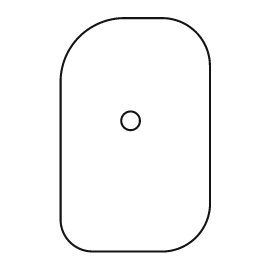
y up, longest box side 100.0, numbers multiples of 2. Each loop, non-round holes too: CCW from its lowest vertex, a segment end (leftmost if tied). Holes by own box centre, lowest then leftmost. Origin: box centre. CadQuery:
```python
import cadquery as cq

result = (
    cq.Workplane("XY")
    .moveTo(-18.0, -50.0)
    .lineTo(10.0, -50.0)
    .threePointArc((26.0, -44.0), (32.0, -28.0))
    .lineTo(32.0, 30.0)
    .threePointArc((26.0, 44.0), (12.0, 50.0))
    .lineTo(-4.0, 50.0)
    .threePointArc((-24.0, 42.0), (-32.0, 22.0))
    .lineTo(-32.0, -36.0)
    .threePointArc((-28.0, -46.0), (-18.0, -50.0))
    .close()
    .moveTo(-2.0, 6.0)
    .circle(4.0)
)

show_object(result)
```